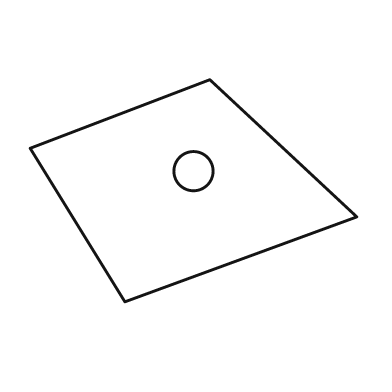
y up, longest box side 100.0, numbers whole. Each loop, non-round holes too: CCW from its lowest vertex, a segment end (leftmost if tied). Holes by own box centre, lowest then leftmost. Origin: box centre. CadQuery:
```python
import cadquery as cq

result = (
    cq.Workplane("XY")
    .moveTo(-21.0, -34.0)
    .lineTo(50.0, -8.0)
    .lineTo(5.0, 34.0)
    .lineTo(-50.0, 13.0)
    .close()
    .moveTo(0.0, 6.0)
    .circle(6.0)
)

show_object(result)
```